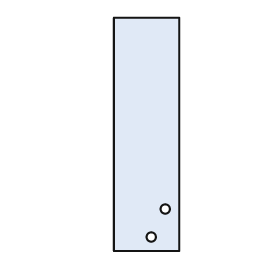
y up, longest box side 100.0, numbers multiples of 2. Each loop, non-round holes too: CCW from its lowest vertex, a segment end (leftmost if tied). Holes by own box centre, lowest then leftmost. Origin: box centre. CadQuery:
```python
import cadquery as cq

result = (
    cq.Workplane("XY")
    .moveTo(-14.0, -50.0)
    .lineTo(14.0, -50.0)
    .lineTo(14.0, 50.0)
    .lineTo(-14.0, 50.0)
    .close()
    .moveTo(2.0, -44.0)
    .circle(2.0)
    .moveTo(8.0, -32.0)
    .circle(2.0)
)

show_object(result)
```